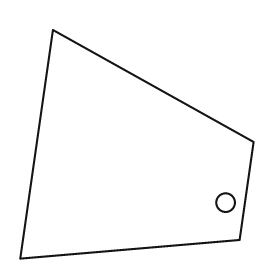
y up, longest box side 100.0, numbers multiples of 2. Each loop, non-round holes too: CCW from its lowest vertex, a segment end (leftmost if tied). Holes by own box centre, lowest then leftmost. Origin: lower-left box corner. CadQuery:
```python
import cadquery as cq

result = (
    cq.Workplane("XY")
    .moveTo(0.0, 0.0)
    .lineTo(94.0, 8.0)
    .lineTo(100.0, 50.0)
    .lineTo(14.0, 98.0)
    .close()
    .moveTo(88.0, 24.0)
    .circle(4.0)
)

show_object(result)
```